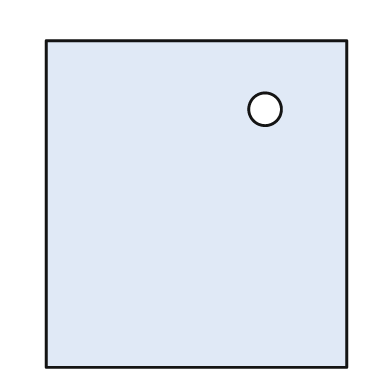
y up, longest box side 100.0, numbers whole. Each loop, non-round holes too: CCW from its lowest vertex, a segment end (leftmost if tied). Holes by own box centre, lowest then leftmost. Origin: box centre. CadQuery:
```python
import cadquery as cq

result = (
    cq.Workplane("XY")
    .moveTo(-46.0, -50.0)
    .lineTo(46.0, -50.0)
    .lineTo(46.0, 50.0)
    .lineTo(-46.0, 50.0)
    .close()
    .moveTo(21.0, 29.0)
    .circle(5.0)
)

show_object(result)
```